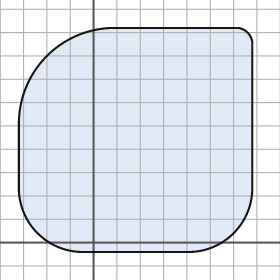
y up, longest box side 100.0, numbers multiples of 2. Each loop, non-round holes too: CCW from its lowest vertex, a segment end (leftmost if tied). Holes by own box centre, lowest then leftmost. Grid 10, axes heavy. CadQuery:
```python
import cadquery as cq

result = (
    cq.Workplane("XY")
    .moveTo(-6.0, -4.0)
    .lineTo(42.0, -4.0)
    .threePointArc((60.0, 4.0), (68.0, 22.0))
    .lineTo(68.0, 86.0)
    .threePointArc((66.0, 90.0), (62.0, 92.0))
    .lineTo(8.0, 92.0)
    .threePointArc((-20.0, 80.0), (-32.0, 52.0))
    .lineTo(-32.0, 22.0)
    .threePointArc((-24.0, 4.0), (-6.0, -4.0))
    .close()
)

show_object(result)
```